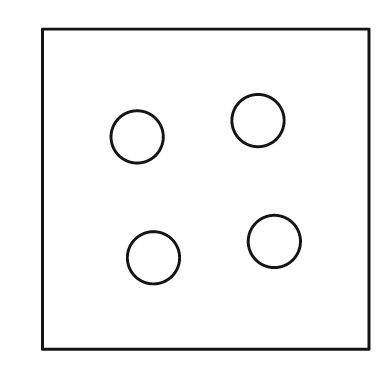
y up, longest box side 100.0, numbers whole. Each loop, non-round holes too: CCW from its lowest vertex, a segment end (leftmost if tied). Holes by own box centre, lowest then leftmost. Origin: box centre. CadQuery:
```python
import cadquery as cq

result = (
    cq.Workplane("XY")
    .moveTo(-50.0, -49.0)
    .lineTo(50.0, -49.0)
    .lineTo(50.0, 49.0)
    .lineTo(-50.0, 49.0)
    .close()
    .moveTo(-16.0, -21.0)
    .circle(8.0)
    .moveTo(21.0, -16.0)
    .circle(8.0)
    .moveTo(-21.0, 16.0)
    .circle(8.0)
    .moveTo(16.0, 21.0)
    .circle(8.0)
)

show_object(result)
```